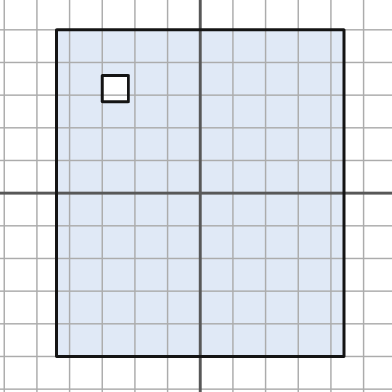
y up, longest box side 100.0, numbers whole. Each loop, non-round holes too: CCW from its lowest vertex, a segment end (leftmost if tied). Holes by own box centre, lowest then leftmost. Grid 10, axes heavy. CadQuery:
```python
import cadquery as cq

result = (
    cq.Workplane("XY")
    .moveTo(-44.0, -50.0)
    .lineTo(44.0, -50.0)
    .lineTo(44.0, 50.0)
    .lineTo(-44.0, 50.0)
    .close()
    .moveTo(-30.0, 28.0)
    .lineTo(-22.0, 28.0)
    .lineTo(-22.0, 36.0)
    .lineTo(-30.0, 36.0)
    .close()
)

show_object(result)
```